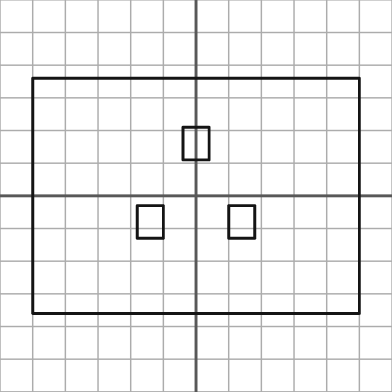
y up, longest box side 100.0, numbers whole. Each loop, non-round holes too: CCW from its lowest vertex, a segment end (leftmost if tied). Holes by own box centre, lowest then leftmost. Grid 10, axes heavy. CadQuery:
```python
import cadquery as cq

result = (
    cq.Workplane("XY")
    .moveTo(-50.0, -36.0)
    .lineTo(50.0, -36.0)
    .lineTo(50.0, 36.0)
    .lineTo(-50.0, 36.0)
    .close()
    .moveTo(-18.0, -13.0)
    .lineTo(-10.0, -13.0)
    .lineTo(-10.0, -3.0)
    .lineTo(-18.0, -3.0)
    .close()
    .moveTo(10.0, -13.0)
    .lineTo(18.0, -13.0)
    .lineTo(18.0, -3.0)
    .lineTo(10.0, -3.0)
    .close()
    .moveTo(-4.0, 11.0)
    .lineTo(4.0, 11.0)
    .lineTo(4.0, 21.0)
    .lineTo(-4.0, 21.0)
    .close()
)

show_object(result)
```